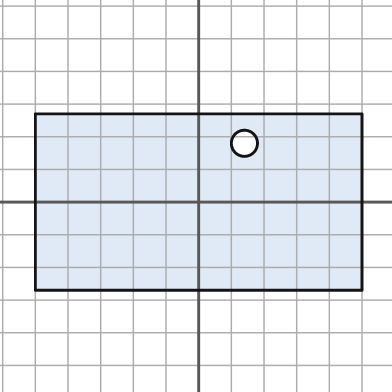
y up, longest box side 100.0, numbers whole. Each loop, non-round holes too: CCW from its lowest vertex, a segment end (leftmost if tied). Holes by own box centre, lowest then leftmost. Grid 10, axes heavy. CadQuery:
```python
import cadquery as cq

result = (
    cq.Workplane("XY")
    .moveTo(-50.0, -27.0)
    .lineTo(50.0, -27.0)
    .lineTo(50.0, 27.0)
    .lineTo(-50.0, 27.0)
    .close()
    .moveTo(14.0, 18.0)
    .circle(4.0)
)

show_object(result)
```